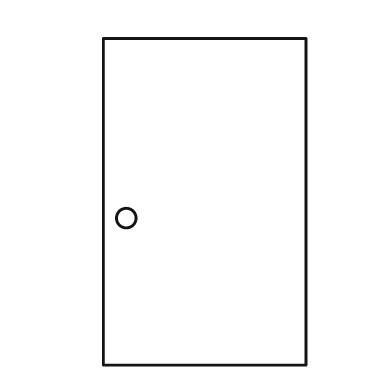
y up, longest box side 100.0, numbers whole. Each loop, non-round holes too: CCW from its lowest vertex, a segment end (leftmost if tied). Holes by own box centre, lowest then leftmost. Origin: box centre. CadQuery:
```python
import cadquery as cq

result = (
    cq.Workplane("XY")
    .moveTo(-31.0, -50.0)
    .lineTo(31.0, -50.0)
    .lineTo(31.0, 50.0)
    .lineTo(-31.0, 50.0)
    .close()
    .moveTo(-24.0, -5.0)
    .circle(3.0)
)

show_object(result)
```